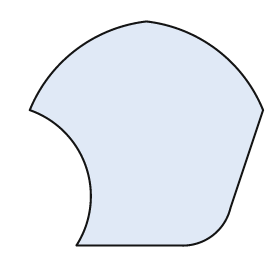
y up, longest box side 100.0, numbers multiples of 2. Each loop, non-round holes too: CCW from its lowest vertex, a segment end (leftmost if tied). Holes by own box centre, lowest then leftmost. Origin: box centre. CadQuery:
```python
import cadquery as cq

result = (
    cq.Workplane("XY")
    .moveTo(-30.0, -48.0)
    .lineTo(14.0, -48.0)
    .threePointArc((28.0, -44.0), (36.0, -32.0))
    .lineTo(50.0, 10.0)
    .threePointArc((30.0, 36.0), (0.0, 48.0))
    .threePointArc((-30.0, 36.0), (-50.0, 10.0))
    .threePointArc((-26.0, -14.0), (-30.0, -48.0))
    .close()
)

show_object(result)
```